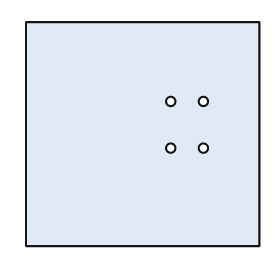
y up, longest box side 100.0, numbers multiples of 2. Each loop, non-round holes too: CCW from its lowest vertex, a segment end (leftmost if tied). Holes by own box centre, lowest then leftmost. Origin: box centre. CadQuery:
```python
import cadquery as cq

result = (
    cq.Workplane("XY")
    .moveTo(-50.0, -48.0)
    .lineTo(50.0, -48.0)
    .lineTo(50.0, 48.0)
    .lineTo(-50.0, 48.0)
    .close()
    .moveTo(12.0, -6.0)
    .circle(2.0)
    .moveTo(26.0, -6.0)
    .circle(2.0)
    .moveTo(12.0, 14.0)
    .circle(2.0)
    .moveTo(26.0, 14.0)
    .circle(2.0)
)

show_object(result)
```